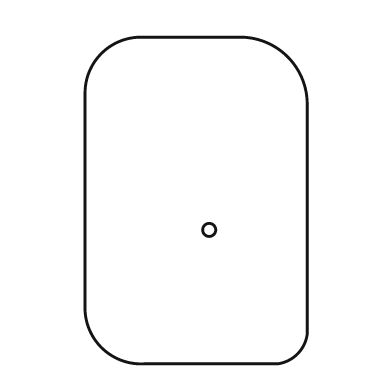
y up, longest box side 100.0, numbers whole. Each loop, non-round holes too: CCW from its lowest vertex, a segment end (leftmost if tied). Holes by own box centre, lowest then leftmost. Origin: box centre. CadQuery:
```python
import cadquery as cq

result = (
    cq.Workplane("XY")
    .moveTo(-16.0, -50.0)
    .lineTo(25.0, -50.0)
    .threePointArc((31.0, -47.0), (34.0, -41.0))
    .lineTo(34.0, 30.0)
    .threePointArc((28.0, 44.0), (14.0, 50.0))
    .lineTo(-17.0, 50.0)
    .threePointArc((-29.0, 45.0), (-34.0, 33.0))
    .lineTo(-34.0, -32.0)
    .threePointArc((-29.0, -45.0), (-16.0, -50.0))
    .close()
    .moveTo(4.0, -9.0)
    .circle(2.0)
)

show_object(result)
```